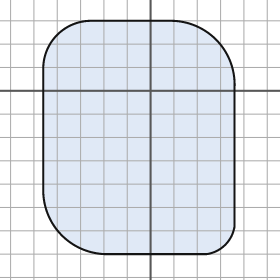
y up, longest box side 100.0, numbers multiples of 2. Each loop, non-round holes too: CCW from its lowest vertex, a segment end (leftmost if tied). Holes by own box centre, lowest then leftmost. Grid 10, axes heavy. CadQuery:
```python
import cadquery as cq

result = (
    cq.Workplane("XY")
    .moveTo(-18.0, -70.0)
    .lineTo(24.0, -70.0)
    .threePointArc((32.0, -66.0), (36.0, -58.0))
    .lineTo(36.0, 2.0)
    .threePointArc((28.0, 22.0), (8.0, 30.0))
    .lineTo(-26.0, 30.0)
    .threePointArc((-40.0, 24.0), (-46.0, 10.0))
    .lineTo(-46.0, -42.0)
    .threePointArc((-38.0, -62.0), (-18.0, -70.0))
    .close()
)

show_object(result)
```